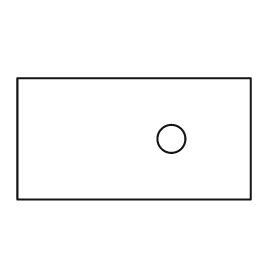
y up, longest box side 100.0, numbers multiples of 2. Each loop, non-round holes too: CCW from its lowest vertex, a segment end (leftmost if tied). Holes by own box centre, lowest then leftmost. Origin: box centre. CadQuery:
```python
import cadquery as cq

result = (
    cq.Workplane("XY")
    .moveTo(-50.0, -26.0)
    .lineTo(50.0, -26.0)
    .lineTo(50.0, 26.0)
    .lineTo(-50.0, 26.0)
    .close()
    .moveTo(16.0, 0.0)
    .circle(6.0)
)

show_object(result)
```